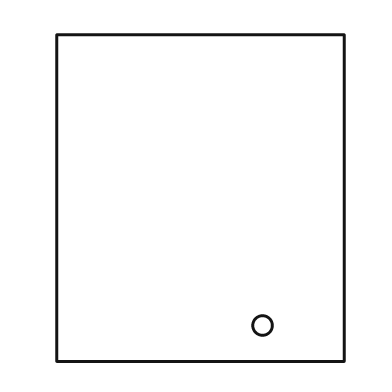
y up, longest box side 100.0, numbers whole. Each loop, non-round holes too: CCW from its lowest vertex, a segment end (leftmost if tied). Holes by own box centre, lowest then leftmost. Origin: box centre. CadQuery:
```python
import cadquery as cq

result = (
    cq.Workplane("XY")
    .moveTo(-44.0, -50.0)
    .lineTo(44.0, -50.0)
    .lineTo(44.0, 50.0)
    .lineTo(-44.0, 50.0)
    .close()
    .moveTo(19.0, -39.0)
    .circle(3.0)
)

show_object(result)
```